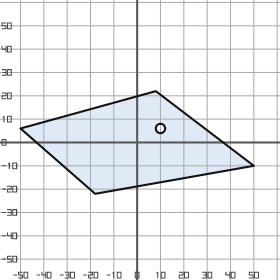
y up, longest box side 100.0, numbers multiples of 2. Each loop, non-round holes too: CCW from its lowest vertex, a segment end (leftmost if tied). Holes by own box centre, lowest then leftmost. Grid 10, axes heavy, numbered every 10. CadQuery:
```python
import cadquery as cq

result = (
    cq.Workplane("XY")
    .moveTo(-18.0, -22.0)
    .lineTo(50.0, -10.0)
    .lineTo(8.0, 22.0)
    .lineTo(-50.0, 6.0)
    .close()
    .moveTo(10.0, 6.0)
    .circle(2.0)
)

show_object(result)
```